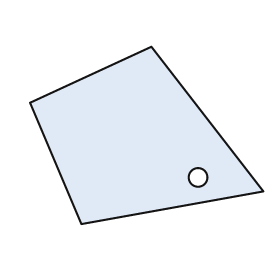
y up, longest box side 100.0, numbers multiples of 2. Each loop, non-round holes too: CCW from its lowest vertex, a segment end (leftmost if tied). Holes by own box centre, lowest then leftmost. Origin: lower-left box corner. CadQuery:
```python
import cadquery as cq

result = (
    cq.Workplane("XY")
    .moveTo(22.0, 0.0)
    .lineTo(100.0, 14.0)
    .lineTo(52.0, 76.0)
    .lineTo(0.0, 52.0)
    .close()
    .moveTo(72.0, 20.0)
    .circle(4.0)
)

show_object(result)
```